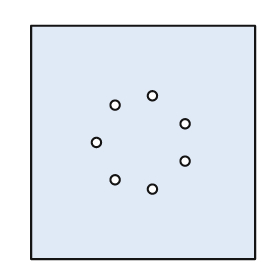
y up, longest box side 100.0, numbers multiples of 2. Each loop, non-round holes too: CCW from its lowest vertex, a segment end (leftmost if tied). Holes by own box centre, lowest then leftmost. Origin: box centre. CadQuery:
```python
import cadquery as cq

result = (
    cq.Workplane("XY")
    .moveTo(-48.0, -50.0)
    .lineTo(48.0, -50.0)
    .lineTo(48.0, 50.0)
    .lineTo(-48.0, 50.0)
    .close()
    .moveTo(4.0, -20.0)
    .circle(2.0)
    .moveTo(-12.0, -16.0)
    .circle(2.0)
    .moveTo(18.0, -8.0)
    .circle(2.0)
    .moveTo(-20.0, 0.0)
    .circle(2.0)
    .moveTo(18.0, 8.0)
    .circle(2.0)
    .moveTo(-12.0, 16.0)
    .circle(2.0)
    .moveTo(4.0, 20.0)
    .circle(2.0)
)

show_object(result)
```